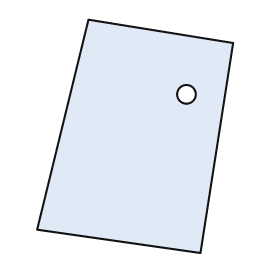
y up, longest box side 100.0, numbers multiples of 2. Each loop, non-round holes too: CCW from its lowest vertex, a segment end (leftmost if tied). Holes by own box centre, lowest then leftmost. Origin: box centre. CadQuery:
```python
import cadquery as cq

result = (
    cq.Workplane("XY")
    .moveTo(28.0, -50.0)
    .lineTo(42.0, 40.0)
    .lineTo(-20.0, 50.0)
    .lineTo(-42.0, -40.0)
    .close()
    .moveTo(22.0, 18.0)
    .circle(4.0)
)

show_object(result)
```